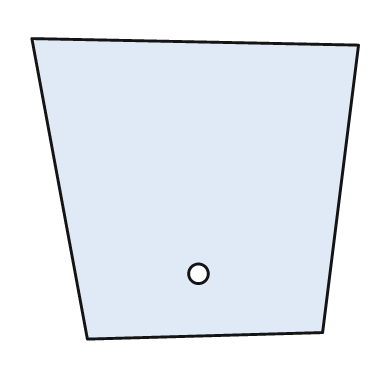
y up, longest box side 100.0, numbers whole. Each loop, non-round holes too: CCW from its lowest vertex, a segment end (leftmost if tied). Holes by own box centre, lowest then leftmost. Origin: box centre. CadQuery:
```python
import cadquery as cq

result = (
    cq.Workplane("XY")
    .moveTo(-33.0, -46.0)
    .lineTo(39.0, -44.0)
    .lineTo(50.0, 44.0)
    .lineTo(-50.0, 46.0)
    .close()
    .moveTo(1.0, -26.0)
    .circle(3.0)
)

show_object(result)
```